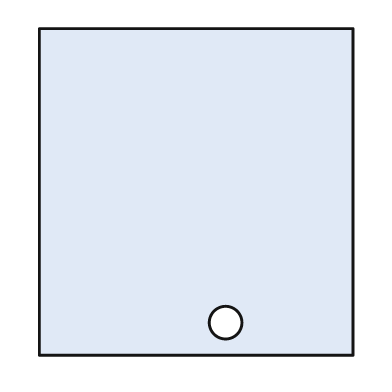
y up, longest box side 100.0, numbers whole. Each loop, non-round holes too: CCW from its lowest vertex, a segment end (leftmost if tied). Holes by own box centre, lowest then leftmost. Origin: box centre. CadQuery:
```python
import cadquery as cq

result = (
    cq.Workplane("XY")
    .moveTo(-48.0, -50.0)
    .lineTo(48.0, -50.0)
    .lineTo(48.0, 50.0)
    .lineTo(-48.0, 50.0)
    .close()
    .moveTo(9.0, -40.0)
    .circle(5.0)
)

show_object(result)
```